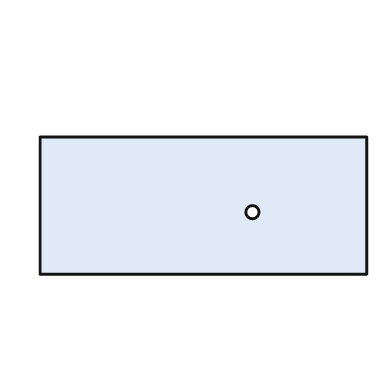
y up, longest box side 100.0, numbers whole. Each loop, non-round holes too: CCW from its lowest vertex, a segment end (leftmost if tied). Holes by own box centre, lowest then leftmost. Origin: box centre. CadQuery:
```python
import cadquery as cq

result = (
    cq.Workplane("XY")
    .moveTo(-50.0, -21.0)
    .lineTo(50.0, -21.0)
    .lineTo(50.0, 21.0)
    .lineTo(-50.0, 21.0)
    .close()
    .moveTo(15.0, -2.0)
    .circle(2.0)
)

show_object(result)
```